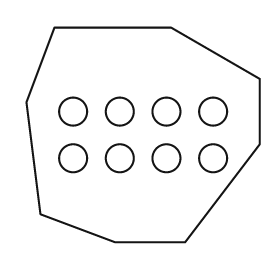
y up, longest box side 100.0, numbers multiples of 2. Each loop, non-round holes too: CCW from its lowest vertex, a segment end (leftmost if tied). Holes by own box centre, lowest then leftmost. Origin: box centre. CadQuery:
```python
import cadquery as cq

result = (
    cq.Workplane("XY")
    .moveTo(-12.0, -46.0)
    .lineTo(18.0, -46.0)
    .lineTo(50.0, -4.0)
    .lineTo(50.0, 24.0)
    .lineTo(12.0, 46.0)
    .lineTo(-38.0, 46.0)
    .lineTo(-50.0, 14.0)
    .lineTo(-44.0, -34.0)
    .close()
    .moveTo(-30.0, -10.0)
    .circle(6.0)
    .moveTo(-10.0, -10.0)
    .circle(6.0)
    .moveTo(10.0, -10.0)
    .circle(6.0)
    .moveTo(30.0, -10.0)
    .circle(6.0)
    .moveTo(-30.0, 10.0)
    .circle(6.0)
    .moveTo(-10.0, 10.0)
    .circle(6.0)
    .moveTo(10.0, 10.0)
    .circle(6.0)
    .moveTo(30.0, 10.0)
    .circle(6.0)
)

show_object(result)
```